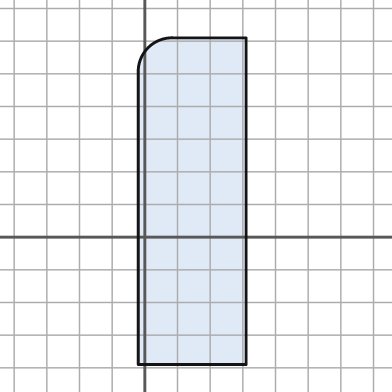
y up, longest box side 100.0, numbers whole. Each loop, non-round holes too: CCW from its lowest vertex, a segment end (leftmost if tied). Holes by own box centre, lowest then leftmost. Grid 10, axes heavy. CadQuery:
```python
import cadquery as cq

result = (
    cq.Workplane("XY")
    .moveTo(-2.0, -39.0)
    .lineTo(31.0, -39.0)
    .lineTo(31.0, 61.0)
    .lineTo(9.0, 61.0)
    .threePointArc((1.0, 58.0), (-2.0, 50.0))
    .close()
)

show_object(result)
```